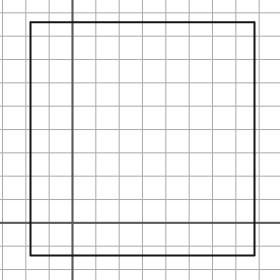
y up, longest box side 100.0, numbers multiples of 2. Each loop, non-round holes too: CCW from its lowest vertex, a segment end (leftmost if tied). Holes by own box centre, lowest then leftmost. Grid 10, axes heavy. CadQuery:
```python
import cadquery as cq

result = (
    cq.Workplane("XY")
    .moveTo(-18.0, -14.0)
    .lineTo(78.0, -14.0)
    .lineTo(78.0, 86.0)
    .lineTo(-18.0, 86.0)
    .close()
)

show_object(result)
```